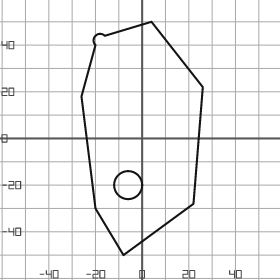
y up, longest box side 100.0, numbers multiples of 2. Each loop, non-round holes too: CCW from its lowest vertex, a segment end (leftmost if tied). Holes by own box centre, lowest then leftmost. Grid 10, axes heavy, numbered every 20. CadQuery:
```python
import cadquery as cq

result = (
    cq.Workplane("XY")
    .moveTo(-8.0, -50.0)
    .lineTo(22.0, -28.0)
    .lineTo(26.0, 22.0)
    .lineTo(4.0, 50.0)
    .lineTo(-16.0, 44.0)
    .threePointArc((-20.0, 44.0), (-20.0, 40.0))
    .lineTo(-26.0, 18.0)
    .lineTo(-20.0, -30.0)
    .close()
    .moveTo(-6.0, -20.0)
    .circle(6.0)
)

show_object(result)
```